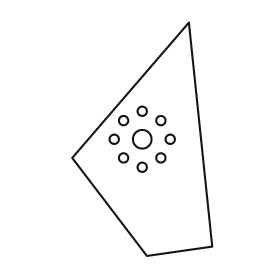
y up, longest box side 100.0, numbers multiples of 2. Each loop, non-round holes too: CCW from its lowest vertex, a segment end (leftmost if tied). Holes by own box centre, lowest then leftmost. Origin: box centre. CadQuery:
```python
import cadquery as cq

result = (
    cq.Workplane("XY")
    .moveTo(2.0, -50.0)
    .lineTo(30.0, -46.0)
    .lineTo(20.0, 50.0)
    .lineTo(-30.0, -8.0)
    .close()
    .moveTo(0.0, -12.0)
    .circle(2.0)
    .moveTo(-8.0, -8.0)
    .circle(2.0)
    .moveTo(8.0, -8.0)
    .circle(2.0)
    .moveTo(-12.0, 0.0)
    .circle(2.0)
    .moveTo(0.0, 0.0)
    .circle(4.0)
    .moveTo(12.0, 0.0)
    .circle(2.0)
    .moveTo(-8.0, 8.0)
    .circle(2.0)
    .moveTo(8.0, 8.0)
    .circle(2.0)
    .moveTo(0.0, 12.0)
    .circle(2.0)
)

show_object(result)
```